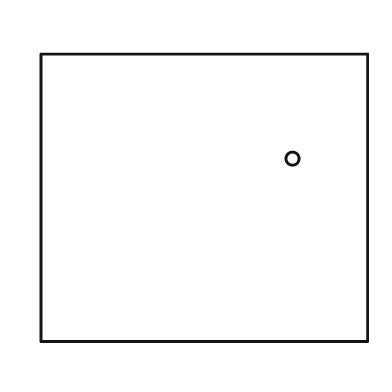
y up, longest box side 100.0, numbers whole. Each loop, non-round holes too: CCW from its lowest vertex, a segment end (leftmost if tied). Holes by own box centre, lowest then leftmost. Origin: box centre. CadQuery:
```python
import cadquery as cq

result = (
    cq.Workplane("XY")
    .moveTo(-50.0, -44.0)
    .lineTo(50.0, -44.0)
    .lineTo(50.0, 44.0)
    .lineTo(-50.0, 44.0)
    .close()
    .moveTo(27.0, 12.0)
    .circle(2.0)
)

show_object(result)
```